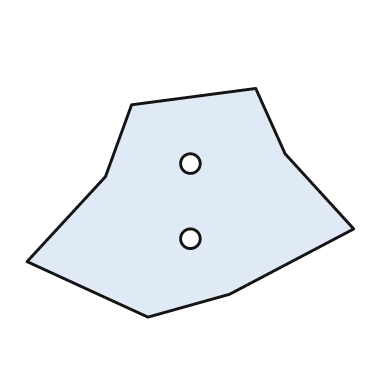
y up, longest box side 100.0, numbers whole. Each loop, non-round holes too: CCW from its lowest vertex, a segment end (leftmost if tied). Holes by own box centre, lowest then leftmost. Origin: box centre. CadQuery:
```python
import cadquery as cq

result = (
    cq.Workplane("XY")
    .moveTo(-13.0, -35.0)
    .lineTo(12.0, -28.0)
    .lineTo(50.0, -8.0)
    .lineTo(29.0, 15.0)
    .lineTo(20.0, 35.0)
    .lineTo(-18.0, 30.0)
    .lineTo(-26.0, 8.0)
    .lineTo(-50.0, -18.0)
    .close()
    .moveTo(0.0, -11.0)
    .circle(3.0)
    .moveTo(0.0, 12.0)
    .circle(3.0)
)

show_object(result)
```